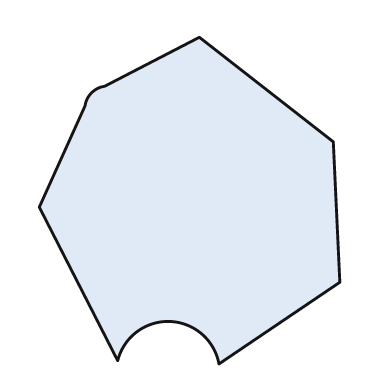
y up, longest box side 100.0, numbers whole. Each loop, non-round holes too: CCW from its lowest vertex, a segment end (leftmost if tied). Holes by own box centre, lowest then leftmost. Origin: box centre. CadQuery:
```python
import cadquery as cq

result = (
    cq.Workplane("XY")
    .moveTo(9.0, -50.0)
    .lineTo(46.0, -25.0)
    .lineTo(44.0, 18.0)
    .lineTo(3.0, 50.0)
    .lineTo(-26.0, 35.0)
    .threePointArc((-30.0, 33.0), (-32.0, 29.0))
    .lineTo(-46.0, -2.0)
    .lineTo(-22.0, -49.0)
    .threePointArc((-6.0, -37.0), (9.0, -50.0))
    .close()
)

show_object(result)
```